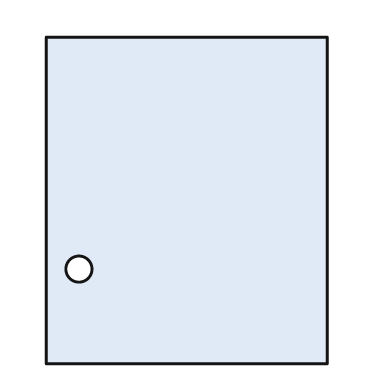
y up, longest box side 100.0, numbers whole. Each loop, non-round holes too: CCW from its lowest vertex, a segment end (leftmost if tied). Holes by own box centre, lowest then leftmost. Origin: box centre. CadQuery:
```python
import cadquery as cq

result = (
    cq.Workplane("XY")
    .moveTo(-43.0, -50.0)
    .lineTo(43.0, -50.0)
    .lineTo(43.0, 50.0)
    .lineTo(-43.0, 50.0)
    .close()
    .moveTo(-33.0, -21.0)
    .circle(4.0)
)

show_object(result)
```